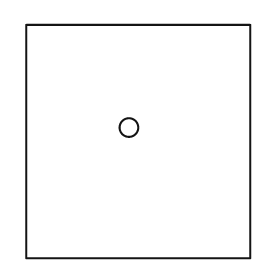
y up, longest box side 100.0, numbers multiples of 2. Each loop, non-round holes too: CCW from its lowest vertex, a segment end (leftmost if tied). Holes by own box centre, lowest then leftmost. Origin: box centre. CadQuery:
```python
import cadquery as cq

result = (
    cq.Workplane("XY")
    .moveTo(-48.0, -50.0)
    .lineTo(48.0, -50.0)
    .lineTo(48.0, 50.0)
    .lineTo(-48.0, 50.0)
    .close()
    .moveTo(-4.0, 6.0)
    .circle(4.0)
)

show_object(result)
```